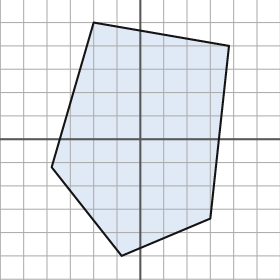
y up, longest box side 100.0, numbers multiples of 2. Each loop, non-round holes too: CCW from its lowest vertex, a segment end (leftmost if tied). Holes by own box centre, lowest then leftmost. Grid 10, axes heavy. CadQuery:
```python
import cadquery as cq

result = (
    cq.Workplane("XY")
    .moveTo(-8.0, -50.0)
    .lineTo(30.0, -34.0)
    .lineTo(38.0, 40.0)
    .lineTo(-20.0, 50.0)
    .lineTo(-38.0, -12.0)
    .close()
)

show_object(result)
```